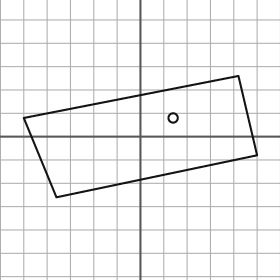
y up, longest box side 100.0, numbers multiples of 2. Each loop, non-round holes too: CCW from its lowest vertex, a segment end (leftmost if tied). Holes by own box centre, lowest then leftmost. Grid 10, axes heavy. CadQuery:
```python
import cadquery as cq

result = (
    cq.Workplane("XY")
    .moveTo(-36.0, -26.0)
    .lineTo(50.0, -8.0)
    .lineTo(42.0, 26.0)
    .lineTo(-50.0, 8.0)
    .close()
    .moveTo(14.0, 8.0)
    .circle(2.0)
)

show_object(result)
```